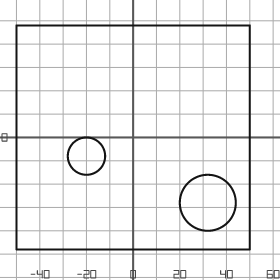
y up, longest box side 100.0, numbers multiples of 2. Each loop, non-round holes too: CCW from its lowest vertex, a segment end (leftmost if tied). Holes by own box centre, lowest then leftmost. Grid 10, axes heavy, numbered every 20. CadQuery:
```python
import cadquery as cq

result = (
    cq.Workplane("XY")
    .moveTo(-50.0, -48.0)
    .lineTo(50.0, -48.0)
    .lineTo(50.0, 48.0)
    .lineTo(-50.0, 48.0)
    .close()
    .moveTo(32.0, -28.0)
    .circle(12.0)
    .moveTo(-20.0, -8.0)
    .circle(8.0)
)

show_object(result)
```